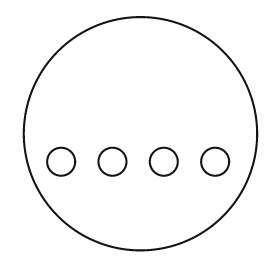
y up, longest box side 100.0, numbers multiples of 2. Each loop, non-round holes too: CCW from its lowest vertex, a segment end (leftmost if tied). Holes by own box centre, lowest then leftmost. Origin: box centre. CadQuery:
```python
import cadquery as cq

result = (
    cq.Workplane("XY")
    .moveTo(0.0, 0.0)
    .circle(50.0)
    .moveTo(-34.0, -12.0)
    .circle(6.0)
    .moveTo(-12.0, -12.0)
    .circle(6.0)
    .moveTo(10.0, -12.0)
    .circle(6.0)
    .moveTo(32.0, -12.0)
    .circle(6.0)
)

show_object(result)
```